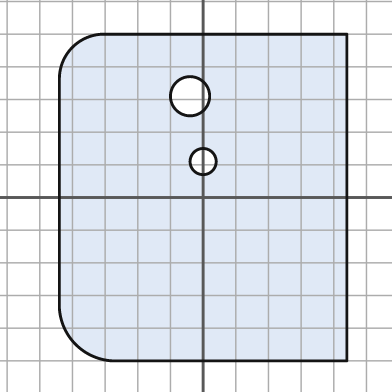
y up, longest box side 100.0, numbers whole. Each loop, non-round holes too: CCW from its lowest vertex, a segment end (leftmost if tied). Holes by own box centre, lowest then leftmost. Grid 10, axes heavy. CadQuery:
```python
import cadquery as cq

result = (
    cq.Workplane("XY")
    .moveTo(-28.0, -50.0)
    .lineTo(44.0, -50.0)
    .lineTo(44.0, 50.0)
    .lineTo(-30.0, 50.0)
    .threePointArc((-40.0, 46.0), (-44.0, 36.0))
    .lineTo(-44.0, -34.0)
    .threePointArc((-39.0, -45.0), (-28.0, -50.0))
    .close()
    .moveTo(0.0, 11.0)
    .circle(4.0)
    .moveTo(-4.0, 31.0)
    .circle(6.0)
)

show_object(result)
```